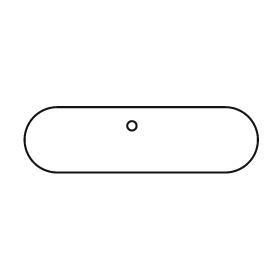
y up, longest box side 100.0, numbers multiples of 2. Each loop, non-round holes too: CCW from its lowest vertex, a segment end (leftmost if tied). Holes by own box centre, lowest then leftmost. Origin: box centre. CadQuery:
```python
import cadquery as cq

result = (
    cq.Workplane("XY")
    .moveTo(-36.0, -14.0)
    .lineTo(36.0, -14.0)
    .threePointArc((50.0, 0.0), (36.0, 14.0))
    .lineTo(-36.0, 14.0)
    .threePointArc((-50.0, 0.0), (-36.0, -14.0))
    .close()
    .moveTo(-4.0, 6.0)
    .circle(2.0)
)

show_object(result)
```